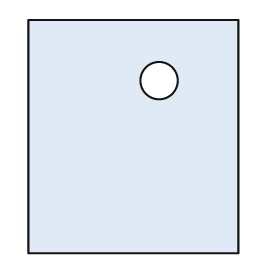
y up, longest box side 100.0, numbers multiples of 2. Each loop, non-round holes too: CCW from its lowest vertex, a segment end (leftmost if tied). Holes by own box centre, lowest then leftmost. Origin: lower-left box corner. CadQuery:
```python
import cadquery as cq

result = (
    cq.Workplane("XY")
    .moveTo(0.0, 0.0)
    .lineTo(90.0, 0.0)
    .lineTo(90.0, 100.0)
    .lineTo(0.0, 100.0)
    .close()
    .moveTo(56.0, 74.0)
    .circle(8.0)
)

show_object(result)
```